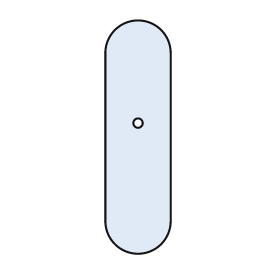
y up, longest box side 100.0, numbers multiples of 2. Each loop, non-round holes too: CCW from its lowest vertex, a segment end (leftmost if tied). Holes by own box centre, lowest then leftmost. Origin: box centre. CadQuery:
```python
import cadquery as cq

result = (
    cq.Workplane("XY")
    .moveTo(-14.0, -36.0)
    .threePointArc((0.0, -50.0), (14.0, -36.0))
    .lineTo(14.0, 36.0)
    .threePointArc((0.0, 50.0), (-14.0, 36.0))
    .close()
    .moveTo(0.0, 6.0)
    .circle(2.0)
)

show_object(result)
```